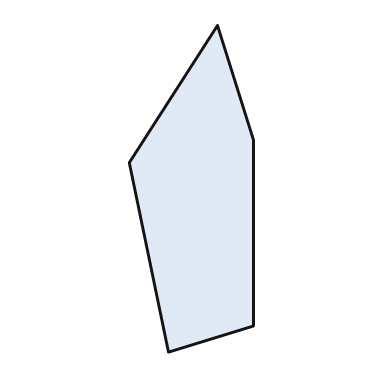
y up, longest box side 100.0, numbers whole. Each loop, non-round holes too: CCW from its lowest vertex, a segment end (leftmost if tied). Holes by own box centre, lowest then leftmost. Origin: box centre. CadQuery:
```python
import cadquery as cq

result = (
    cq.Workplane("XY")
    .moveTo(-7.0, -50.0)
    .lineTo(19.0, -42.0)
    .lineTo(19.0, 15.0)
    .lineTo(8.0, 50.0)
    .lineTo(-19.0, 8.0)
    .close()
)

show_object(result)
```